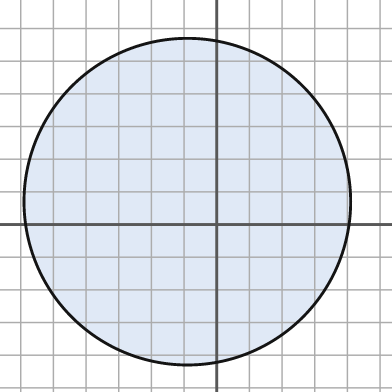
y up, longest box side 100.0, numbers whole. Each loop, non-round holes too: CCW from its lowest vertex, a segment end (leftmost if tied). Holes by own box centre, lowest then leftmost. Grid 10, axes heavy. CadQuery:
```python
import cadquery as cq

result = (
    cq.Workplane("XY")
    .moveTo(-9.0, 7.0)
    .circle(50.0)
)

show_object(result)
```